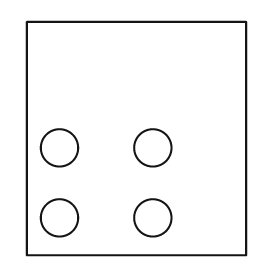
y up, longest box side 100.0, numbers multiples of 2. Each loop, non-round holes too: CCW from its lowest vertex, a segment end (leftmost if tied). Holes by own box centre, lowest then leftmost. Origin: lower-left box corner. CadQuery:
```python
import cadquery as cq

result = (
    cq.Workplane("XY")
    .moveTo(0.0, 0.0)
    .lineTo(94.0, 0.0)
    .lineTo(94.0, 100.0)
    .lineTo(0.0, 100.0)
    .close()
    .moveTo(14.0, 16.0)
    .circle(8.0)
    .moveTo(54.0, 16.0)
    .circle(8.0)
    .moveTo(14.0, 46.0)
    .circle(8.0)
    .moveTo(54.0, 46.0)
    .circle(8.0)
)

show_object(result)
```